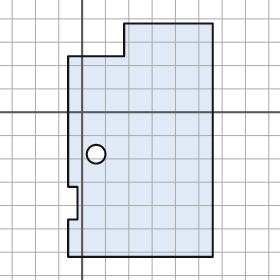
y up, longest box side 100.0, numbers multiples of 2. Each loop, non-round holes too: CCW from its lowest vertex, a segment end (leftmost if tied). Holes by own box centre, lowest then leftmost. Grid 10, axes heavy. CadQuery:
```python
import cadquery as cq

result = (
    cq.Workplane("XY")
    .moveTo(-6.0, -62.0)
    .lineTo(56.0, -62.0)
    .lineTo(56.0, 38.0)
    .lineTo(18.0, 38.0)
    .lineTo(18.0, 24.0)
    .lineTo(-6.0, 24.0)
    .lineTo(-6.0, -32.0)
    .lineTo(-2.0, -32.0)
    .lineTo(-2.0, -46.0)
    .lineTo(-6.0, -46.0)
    .close()
    .moveTo(6.0, -18.0)
    .circle(4.0)
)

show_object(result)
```